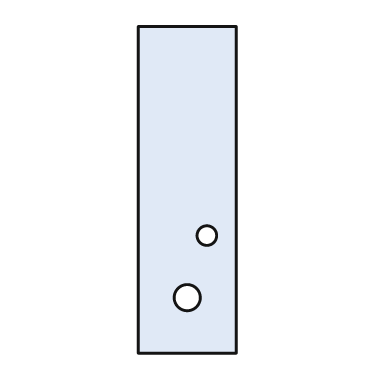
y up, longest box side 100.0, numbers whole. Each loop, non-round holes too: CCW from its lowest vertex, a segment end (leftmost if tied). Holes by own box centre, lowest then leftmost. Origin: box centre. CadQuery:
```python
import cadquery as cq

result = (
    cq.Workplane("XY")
    .moveTo(-15.0, -50.0)
    .lineTo(15.0, -50.0)
    .lineTo(15.0, 50.0)
    .lineTo(-15.0, 50.0)
    .close()
    .moveTo(0.0, -33.0)
    .circle(4.0)
    .moveTo(6.0, -14.0)
    .circle(3.0)
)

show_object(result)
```